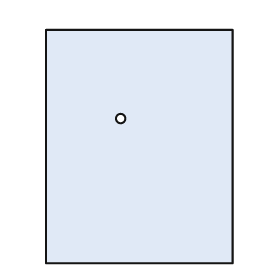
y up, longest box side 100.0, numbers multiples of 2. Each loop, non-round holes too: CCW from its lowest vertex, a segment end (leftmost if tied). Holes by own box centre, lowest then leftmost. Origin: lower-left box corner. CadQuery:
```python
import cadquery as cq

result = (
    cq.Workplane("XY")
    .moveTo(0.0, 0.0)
    .lineTo(80.0, 0.0)
    .lineTo(80.0, 100.0)
    .lineTo(0.0, 100.0)
    .close()
    .moveTo(32.0, 62.0)
    .circle(2.0)
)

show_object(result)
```